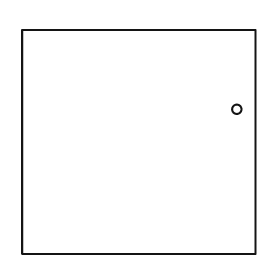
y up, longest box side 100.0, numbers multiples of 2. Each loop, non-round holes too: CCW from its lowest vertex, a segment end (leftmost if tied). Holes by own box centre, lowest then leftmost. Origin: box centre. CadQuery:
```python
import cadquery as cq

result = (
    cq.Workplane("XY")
    .moveTo(-50.0, -48.0)
    .lineTo(50.0, -48.0)
    .lineTo(50.0, 48.0)
    .lineTo(-50.0, 48.0)
    .close()
    .moveTo(42.0, 14.0)
    .circle(2.0)
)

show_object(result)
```